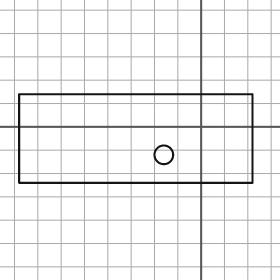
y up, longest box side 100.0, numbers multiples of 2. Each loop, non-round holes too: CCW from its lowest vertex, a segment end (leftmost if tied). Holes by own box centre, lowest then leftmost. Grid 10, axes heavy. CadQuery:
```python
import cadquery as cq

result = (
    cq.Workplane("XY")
    .moveTo(-78.0, -24.0)
    .lineTo(22.0, -24.0)
    .lineTo(22.0, 14.0)
    .lineTo(-78.0, 14.0)
    .close()
    .moveTo(-16.0, -12.0)
    .circle(4.0)
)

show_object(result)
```